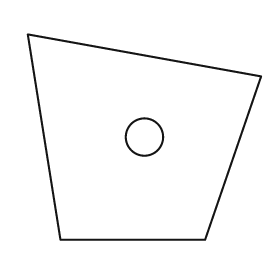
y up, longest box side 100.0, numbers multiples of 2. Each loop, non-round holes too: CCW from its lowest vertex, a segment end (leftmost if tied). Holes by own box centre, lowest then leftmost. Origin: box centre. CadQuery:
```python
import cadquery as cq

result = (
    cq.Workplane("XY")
    .moveTo(-36.0, -44.0)
    .lineTo(26.0, -44.0)
    .lineTo(50.0, 26.0)
    .lineTo(-50.0, 44.0)
    .close()
    .moveTo(0.0, 0.0)
    .circle(8.0)
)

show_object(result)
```